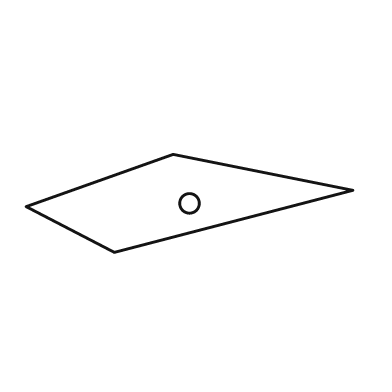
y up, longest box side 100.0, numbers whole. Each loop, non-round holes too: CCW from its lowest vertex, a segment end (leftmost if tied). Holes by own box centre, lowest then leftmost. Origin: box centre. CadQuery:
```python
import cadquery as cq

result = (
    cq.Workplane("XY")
    .moveTo(-23.0, -15.0)
    .lineTo(50.0, 4.0)
    .lineTo(-5.0, 15.0)
    .lineTo(-50.0, -1.0)
    .close()
    .moveTo(0.0, 0.0)
    .circle(3.0)
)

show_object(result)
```